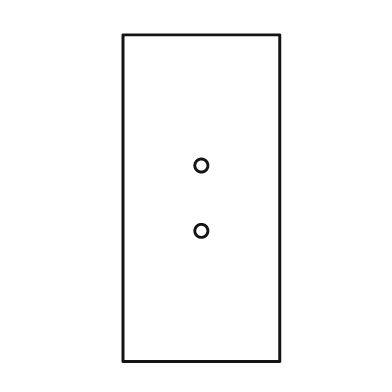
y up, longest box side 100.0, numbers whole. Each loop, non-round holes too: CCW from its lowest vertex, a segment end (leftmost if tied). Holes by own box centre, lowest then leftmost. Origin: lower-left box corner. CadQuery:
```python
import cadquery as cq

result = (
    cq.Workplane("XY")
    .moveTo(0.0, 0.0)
    .lineTo(48.0, 0.0)
    .lineTo(48.0, 100.0)
    .lineTo(0.0, 100.0)
    .close()
    .moveTo(24.0, 40.0)
    .circle(2.0)
    .moveTo(24.0, 60.0)
    .circle(2.0)
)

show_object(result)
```